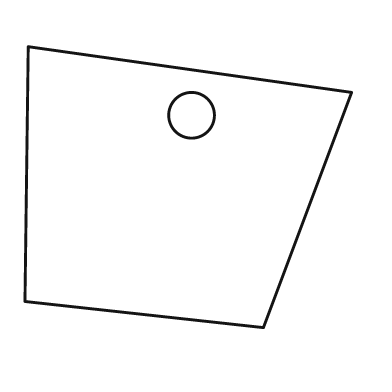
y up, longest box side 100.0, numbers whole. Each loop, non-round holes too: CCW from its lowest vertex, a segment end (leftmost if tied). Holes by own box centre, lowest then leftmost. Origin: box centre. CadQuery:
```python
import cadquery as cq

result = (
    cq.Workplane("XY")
    .moveTo(23.0, -43.0)
    .lineTo(50.0, 29.0)
    .lineTo(-49.0, 43.0)
    .lineTo(-50.0, -35.0)
    .close()
    .moveTo(1.0, 22.0)
    .circle(7.0)
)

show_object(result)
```